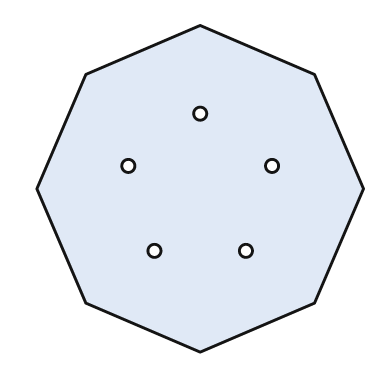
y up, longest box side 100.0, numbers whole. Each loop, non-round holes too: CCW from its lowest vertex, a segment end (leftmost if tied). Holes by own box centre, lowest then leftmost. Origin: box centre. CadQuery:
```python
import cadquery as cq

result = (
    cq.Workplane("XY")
    .moveTo(0.0, -50.0)
    .lineTo(35.0, -35.0)
    .lineTo(50.0, 0.0)
    .lineTo(35.0, 35.0)
    .lineTo(0.0, 50.0)
    .lineTo(-35.0, 35.0)
    .lineTo(-50.0, 0.0)
    .lineTo(-35.0, -35.0)
    .close()
    .moveTo(-14.0, -19.0)
    .circle(2.0)
    .moveTo(14.0, -19.0)
    .circle(2.0)
    .moveTo(-22.0, 7.0)
    .circle(2.0)
    .moveTo(22.0, 7.0)
    .circle(2.0)
    .moveTo(0.0, 23.0)
    .circle(2.0)
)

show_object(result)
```